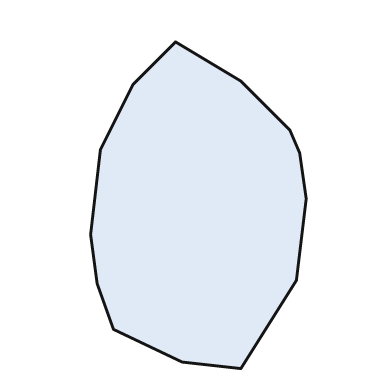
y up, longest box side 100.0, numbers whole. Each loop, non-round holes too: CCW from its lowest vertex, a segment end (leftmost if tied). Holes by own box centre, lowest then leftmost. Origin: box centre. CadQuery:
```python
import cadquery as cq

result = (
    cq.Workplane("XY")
    .moveTo(13.0, -50.0)
    .lineTo(30.0, -23.0)
    .lineTo(33.0, 2.0)
    .lineTo(31.0, 16.0)
    .lineTo(28.0, 23.0)
    .lineTo(13.0, 38.0)
    .lineTo(-7.0, 50.0)
    .lineTo(-20.0, 37.0)
    .lineTo(-30.0, 17.0)
    .lineTo(-33.0, -9.0)
    .lineTo(-31.0, -24.0)
    .lineTo(-26.0, -38.0)
    .lineTo(-5.0, -48.0)
    .close()
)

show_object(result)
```